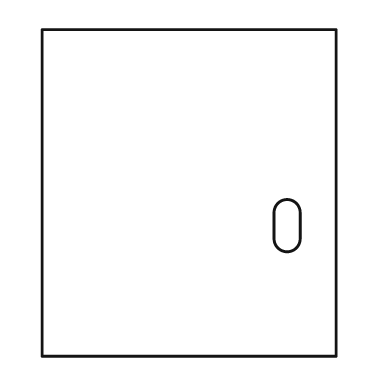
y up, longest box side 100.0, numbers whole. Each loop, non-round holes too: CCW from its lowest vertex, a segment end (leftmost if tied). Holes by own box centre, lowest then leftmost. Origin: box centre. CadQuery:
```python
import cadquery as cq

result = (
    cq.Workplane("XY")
    .moveTo(-45.0, -50.0)
    .lineTo(45.0, -50.0)
    .lineTo(45.0, 50.0)
    .lineTo(-45.0, 50.0)
    .close()
    .moveTo(26.0, -14.0)
    .threePointArc((30.0, -18.0), (34.0, -14.0))
    .lineTo(34.0, -6.0)
    .threePointArc((30.0, -2.0), (26.0, -6.0))
    .close()
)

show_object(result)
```